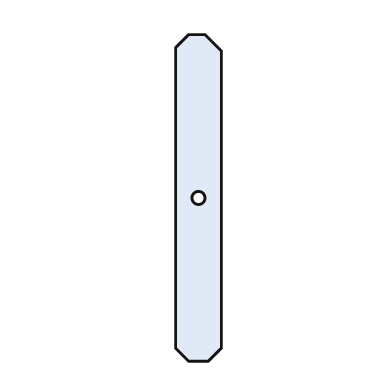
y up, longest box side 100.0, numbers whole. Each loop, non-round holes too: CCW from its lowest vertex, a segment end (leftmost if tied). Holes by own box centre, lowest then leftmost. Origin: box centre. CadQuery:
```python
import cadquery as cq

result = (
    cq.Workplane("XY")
    .moveTo(-3.0, -50.0)
    .lineTo(3.0, -50.0)
    .lineTo(7.0, -46.0)
    .lineTo(7.0, 45.0)
    .lineTo(2.0, 50.0)
    .lineTo(-3.0, 50.0)
    .lineTo(-7.0, 46.0)
    .lineTo(-7.0, -46.0)
    .close()
    .moveTo(0.0, 0.0)
    .circle(2.0)
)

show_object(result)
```